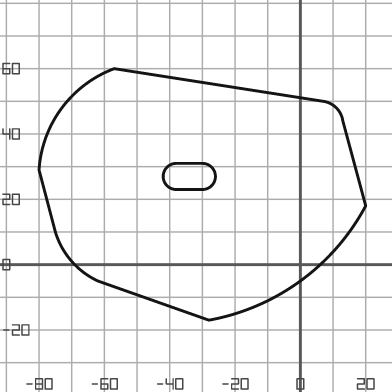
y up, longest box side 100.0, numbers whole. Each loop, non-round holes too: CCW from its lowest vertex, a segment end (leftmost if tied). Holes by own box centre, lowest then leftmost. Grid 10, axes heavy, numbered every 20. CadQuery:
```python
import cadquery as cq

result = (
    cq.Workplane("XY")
    .moveTo(-28.0, -17.0)
    .threePointArc((0.0, -5.0), (20.0, 18.0))
    .lineTo(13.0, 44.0)
    .threePointArc((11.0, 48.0), (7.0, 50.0))
    .lineTo(-57.0, 60.0)
    .threePointArc((-73.0, 48.0), (-80.0, 29.0))
    .lineTo(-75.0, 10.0)
    .threePointArc((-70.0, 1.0), (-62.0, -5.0))
    .close()
    .moveTo(-38.0, 23.0)
    .lineTo(-30.0, 23.0)
    .threePointArc((-26.0, 27.0), (-30.0, 31.0))
    .lineTo(-38.0, 31.0)
    .threePointArc((-42.0, 27.0), (-38.0, 23.0))
    .close()
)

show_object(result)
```